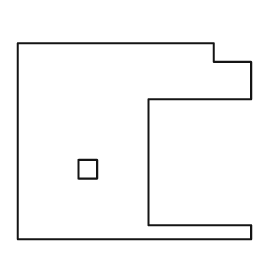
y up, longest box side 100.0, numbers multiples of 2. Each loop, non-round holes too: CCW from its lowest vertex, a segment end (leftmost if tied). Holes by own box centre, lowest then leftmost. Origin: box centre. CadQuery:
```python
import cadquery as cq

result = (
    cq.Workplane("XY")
    .moveTo(-50.0, -42.0)
    .lineTo(50.0, -42.0)
    .lineTo(50.0, -36.0)
    .lineTo(6.0, -36.0)
    .lineTo(6.0, 18.0)
    .lineTo(50.0, 18.0)
    .lineTo(50.0, 34.0)
    .lineTo(34.0, 34.0)
    .lineTo(34.0, 42.0)
    .lineTo(-50.0, 42.0)
    .close()
    .moveTo(-24.0, -16.0)
    .lineTo(-16.0, -16.0)
    .lineTo(-16.0, -8.0)
    .lineTo(-24.0, -8.0)
    .close()
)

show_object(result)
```